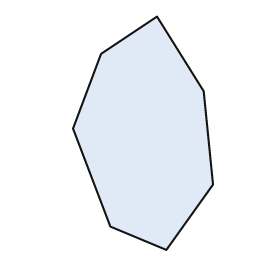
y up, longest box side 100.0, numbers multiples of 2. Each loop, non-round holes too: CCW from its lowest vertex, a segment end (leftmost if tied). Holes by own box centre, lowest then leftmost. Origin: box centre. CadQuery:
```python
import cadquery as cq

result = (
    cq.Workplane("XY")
    .moveTo(10.0, -50.0)
    .lineTo(30.0, -22.0)
    .lineTo(26.0, 18.0)
    .lineTo(6.0, 50.0)
    .lineTo(-18.0, 34.0)
    .lineTo(-30.0, 2.0)
    .lineTo(-14.0, -40.0)
    .close()
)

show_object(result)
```